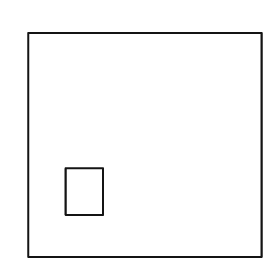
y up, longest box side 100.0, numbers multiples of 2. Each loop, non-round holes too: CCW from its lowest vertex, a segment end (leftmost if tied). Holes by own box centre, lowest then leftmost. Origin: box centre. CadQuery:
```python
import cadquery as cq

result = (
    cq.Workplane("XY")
    .moveTo(-50.0, -48.0)
    .lineTo(50.0, -48.0)
    .lineTo(50.0, 48.0)
    .lineTo(-50.0, 48.0)
    .close()
    .moveTo(-34.0, -30.0)
    .lineTo(-18.0, -30.0)
    .lineTo(-18.0, -10.0)
    .lineTo(-34.0, -10.0)
    .close()
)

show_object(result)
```